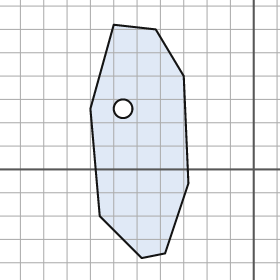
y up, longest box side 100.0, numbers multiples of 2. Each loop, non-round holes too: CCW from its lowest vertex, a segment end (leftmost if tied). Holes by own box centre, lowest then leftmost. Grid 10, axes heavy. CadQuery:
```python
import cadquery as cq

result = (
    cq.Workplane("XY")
    .moveTo(-48.0, -38.0)
    .lineTo(-38.0, -36.0)
    .lineTo(-28.0, -6.0)
    .lineTo(-30.0, 40.0)
    .lineTo(-42.0, 60.0)
    .lineTo(-60.0, 62.0)
    .lineTo(-70.0, 26.0)
    .lineTo(-66.0, -20.0)
    .close()
    .moveTo(-56.0, 26.0)
    .circle(4.0)
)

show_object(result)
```